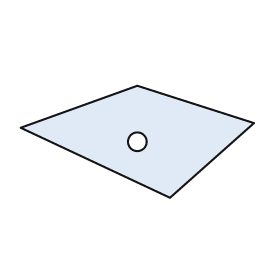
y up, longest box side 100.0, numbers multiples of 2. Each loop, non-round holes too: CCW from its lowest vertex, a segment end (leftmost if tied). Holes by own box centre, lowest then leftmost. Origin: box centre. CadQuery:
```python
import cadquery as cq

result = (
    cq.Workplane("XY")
    .moveTo(14.0, -24.0)
    .lineTo(50.0, 8.0)
    .lineTo(0.0, 24.0)
    .lineTo(-50.0, 6.0)
    .close()
    .moveTo(0.0, 0.0)
    .circle(4.0)
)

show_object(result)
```